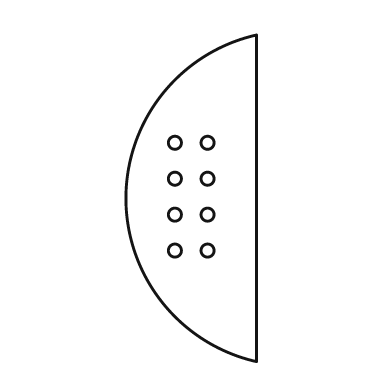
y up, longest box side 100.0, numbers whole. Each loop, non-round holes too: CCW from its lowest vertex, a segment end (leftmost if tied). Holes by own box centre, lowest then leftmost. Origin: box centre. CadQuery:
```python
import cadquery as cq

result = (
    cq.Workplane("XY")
    .moveTo(20.0, -50.0)
    .lineTo(20.0, 50.0)
    .threePointArc((-20.0, 0.0), (20.0, -50.0))
    .close()
    .moveTo(-5.0, -16.0)
    .circle(2.0)
    .moveTo(5.0, -16.0)
    .circle(2.0)
    .moveTo(-5.0, -5.0)
    .circle(2.0)
    .moveTo(5.0, -5.0)
    .circle(2.0)
    .moveTo(-5.0, 6.0)
    .circle(2.0)
    .moveTo(5.0, 6.0)
    .circle(2.0)
    .moveTo(-5.0, 17.0)
    .circle(2.0)
    .moveTo(5.0, 17.0)
    .circle(2.0)
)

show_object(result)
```